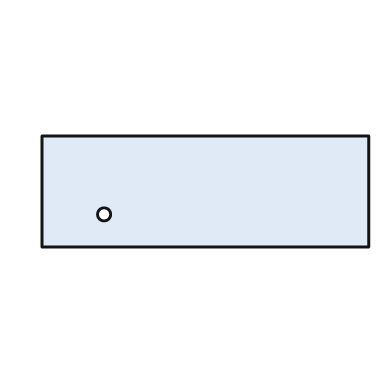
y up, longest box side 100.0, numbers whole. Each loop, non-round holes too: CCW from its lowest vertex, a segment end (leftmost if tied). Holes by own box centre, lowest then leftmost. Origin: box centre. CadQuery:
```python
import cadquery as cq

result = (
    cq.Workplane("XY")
    .moveTo(-50.0, -17.0)
    .lineTo(50.0, -17.0)
    .lineTo(50.0, 17.0)
    .lineTo(-50.0, 17.0)
    .close()
    .moveTo(-31.0, -7.0)
    .circle(2.0)
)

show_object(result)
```